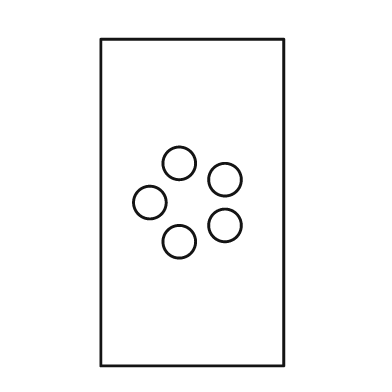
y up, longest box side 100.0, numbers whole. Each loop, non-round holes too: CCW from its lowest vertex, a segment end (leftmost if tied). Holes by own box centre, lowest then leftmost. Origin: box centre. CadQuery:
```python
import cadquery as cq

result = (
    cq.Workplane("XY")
    .moveTo(-28.0, -50.0)
    .lineTo(28.0, -50.0)
    .lineTo(28.0, 50.0)
    .lineTo(-28.0, 50.0)
    .close()
    .moveTo(-4.0, -12.0)
    .circle(5.0)
    .moveTo(10.0, -7.0)
    .circle(5.0)
    .moveTo(-13.0, 0.0)
    .circle(5.0)
    .moveTo(10.0, 7.0)
    .circle(5.0)
    .moveTo(-4.0, 12.0)
    .circle(5.0)
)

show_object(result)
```